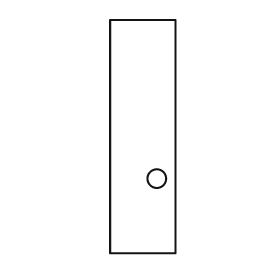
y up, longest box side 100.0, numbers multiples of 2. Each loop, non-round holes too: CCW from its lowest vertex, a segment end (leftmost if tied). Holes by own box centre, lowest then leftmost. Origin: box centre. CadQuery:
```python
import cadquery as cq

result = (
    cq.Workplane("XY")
    .moveTo(-14.0, -50.0)
    .lineTo(14.0, -50.0)
    .lineTo(14.0, 50.0)
    .lineTo(-14.0, 50.0)
    .close()
    .moveTo(6.0, -18.0)
    .circle(4.0)
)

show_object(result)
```